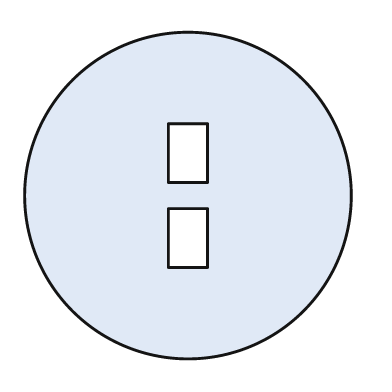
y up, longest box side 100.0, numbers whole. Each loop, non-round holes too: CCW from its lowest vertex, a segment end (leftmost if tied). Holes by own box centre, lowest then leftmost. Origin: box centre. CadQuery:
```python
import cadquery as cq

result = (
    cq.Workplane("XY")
    .moveTo(0.0, 0.0)
    .circle(50.0)
    .moveTo(-6.0, -22.0)
    .lineTo(6.0, -22.0)
    .lineTo(6.0, -4.0)
    .lineTo(-6.0, -4.0)
    .close()
    .moveTo(-6.0, 4.0)
    .lineTo(6.0, 4.0)
    .lineTo(6.0, 22.0)
    .lineTo(-6.0, 22.0)
    .close()
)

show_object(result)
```